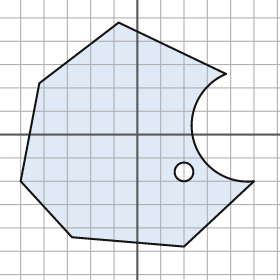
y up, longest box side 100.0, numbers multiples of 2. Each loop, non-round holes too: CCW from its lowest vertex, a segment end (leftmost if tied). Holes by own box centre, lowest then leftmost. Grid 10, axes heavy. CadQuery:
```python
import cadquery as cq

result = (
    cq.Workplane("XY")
    .moveTo(20.0, -48.0)
    .lineTo(50.0, -20.0)
    .threePointArc((24.0, -2.0), (38.0, 26.0))
    .lineTo(-8.0, 48.0)
    .lineTo(-42.0, 22.0)
    .lineTo(-50.0, -20.0)
    .lineTo(-28.0, -44.0)
    .close()
    .moveTo(20.0, -16.0)
    .circle(4.0)
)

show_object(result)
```